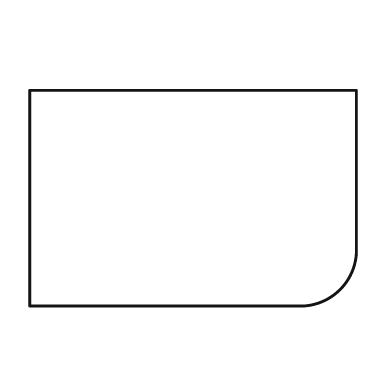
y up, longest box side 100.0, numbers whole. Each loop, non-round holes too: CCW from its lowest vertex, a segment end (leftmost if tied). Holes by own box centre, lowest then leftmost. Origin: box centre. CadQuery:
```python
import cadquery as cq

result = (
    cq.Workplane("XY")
    .moveTo(-50.0, -33.0)
    .lineTo(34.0, -33.0)
    .threePointArc((45.0, -28.0), (50.0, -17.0))
    .lineTo(50.0, 33.0)
    .lineTo(-50.0, 33.0)
    .close()
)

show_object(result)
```